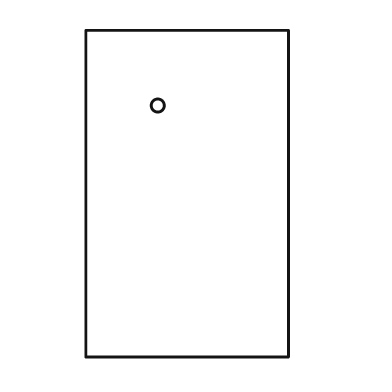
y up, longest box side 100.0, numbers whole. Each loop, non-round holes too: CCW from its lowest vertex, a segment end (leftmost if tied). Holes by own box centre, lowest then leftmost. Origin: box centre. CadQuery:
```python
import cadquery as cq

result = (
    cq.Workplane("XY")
    .moveTo(-31.0, -50.0)
    .lineTo(31.0, -50.0)
    .lineTo(31.0, 50.0)
    .lineTo(-31.0, 50.0)
    .close()
    .moveTo(-9.0, 27.0)
    .circle(2.0)
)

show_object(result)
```